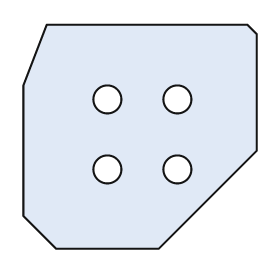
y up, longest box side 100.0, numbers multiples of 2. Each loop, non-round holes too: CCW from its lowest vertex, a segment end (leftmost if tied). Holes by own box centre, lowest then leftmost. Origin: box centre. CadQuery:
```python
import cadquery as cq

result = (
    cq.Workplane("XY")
    .moveTo(-36.0, -48.0)
    .lineTo(8.0, -48.0)
    .lineTo(50.0, -6.0)
    .lineTo(50.0, 44.0)
    .lineTo(46.0, 48.0)
    .lineTo(-40.0, 48.0)
    .lineTo(-50.0, 22.0)
    .lineTo(-50.0, -34.0)
    .close()
    .moveTo(-14.0, -14.0)
    .circle(6.0)
    .moveTo(16.0, -14.0)
    .circle(6.0)
    .moveTo(-14.0, 16.0)
    .circle(6.0)
    .moveTo(16.0, 16.0)
    .circle(6.0)
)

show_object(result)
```